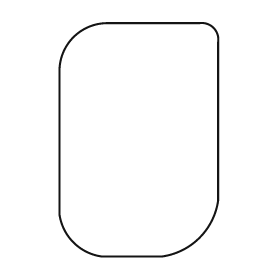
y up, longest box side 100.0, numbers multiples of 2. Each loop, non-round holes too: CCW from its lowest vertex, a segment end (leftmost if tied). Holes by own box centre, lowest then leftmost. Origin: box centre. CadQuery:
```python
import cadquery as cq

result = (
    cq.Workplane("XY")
    .moveTo(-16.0, -50.0)
    .lineTo(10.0, -50.0)
    .threePointArc((26.0, -42.0), (34.0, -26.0))
    .lineTo(34.0, 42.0)
    .threePointArc((32.0, 48.0), (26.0, 50.0))
    .lineTo(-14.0, 50.0)
    .threePointArc((-28.0, 44.0), (-34.0, 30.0))
    .lineTo(-34.0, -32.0)
    .threePointArc((-28.0, -44.0), (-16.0, -50.0))
    .close()
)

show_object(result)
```